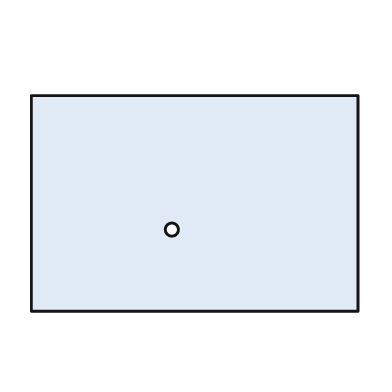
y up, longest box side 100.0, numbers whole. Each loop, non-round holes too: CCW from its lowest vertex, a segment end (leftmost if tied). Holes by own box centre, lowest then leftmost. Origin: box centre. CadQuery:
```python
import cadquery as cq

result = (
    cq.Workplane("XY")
    .moveTo(-50.0, -33.0)
    .lineTo(50.0, -33.0)
    .lineTo(50.0, 33.0)
    .lineTo(-50.0, 33.0)
    .close()
    .moveTo(-7.0, -8.0)
    .circle(2.0)
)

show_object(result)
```